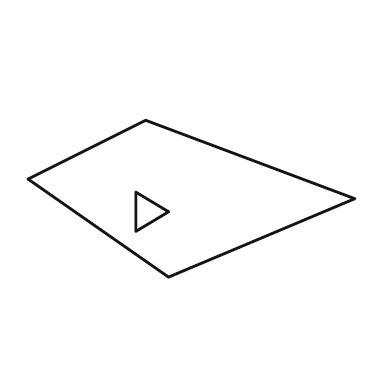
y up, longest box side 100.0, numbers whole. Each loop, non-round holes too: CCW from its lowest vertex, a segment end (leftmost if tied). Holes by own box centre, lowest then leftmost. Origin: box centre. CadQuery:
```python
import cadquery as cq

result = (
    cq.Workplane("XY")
    .moveTo(-7.0, -24.0)
    .lineTo(50.0, 0.0)
    .lineTo(-14.0, 24.0)
    .lineTo(-50.0, 6.0)
    .close()
    .moveTo(-17.0, -10.0)
    .lineTo(-7.0, -4.0)
    .lineTo(-17.0, 2.0)
    .close()
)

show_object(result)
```